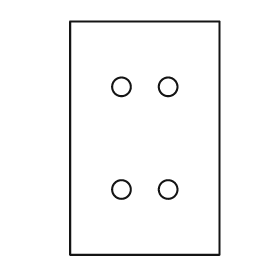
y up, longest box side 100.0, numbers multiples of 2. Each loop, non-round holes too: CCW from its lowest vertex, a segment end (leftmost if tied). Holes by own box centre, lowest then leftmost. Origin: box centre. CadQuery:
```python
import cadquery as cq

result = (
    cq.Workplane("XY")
    .moveTo(-32.0, -50.0)
    .lineTo(32.0, -50.0)
    .lineTo(32.0, 50.0)
    .lineTo(-32.0, 50.0)
    .close()
    .moveTo(-10.0, -22.0)
    .circle(4.0)
    .moveTo(10.0, -22.0)
    .circle(4.0)
    .moveTo(-10.0, 22.0)
    .circle(4.0)
    .moveTo(10.0, 22.0)
    .circle(4.0)
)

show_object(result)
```